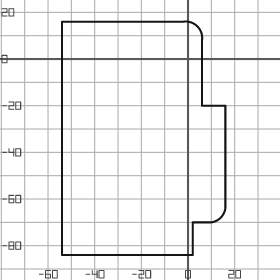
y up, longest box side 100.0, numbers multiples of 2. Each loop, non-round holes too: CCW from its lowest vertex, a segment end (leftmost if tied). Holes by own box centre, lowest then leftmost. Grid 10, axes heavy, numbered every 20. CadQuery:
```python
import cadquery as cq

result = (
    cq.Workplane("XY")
    .moveTo(-54.0, -84.0)
    .lineTo(2.0, -84.0)
    .lineTo(2.0, -70.0)
    .lineTo(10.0, -70.0)
    .threePointArc((14.0, -68.0), (16.0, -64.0))
    .lineTo(16.0, -20.0)
    .lineTo(6.0, -20.0)
    .lineTo(6.0, 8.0)
    .threePointArc((4.0, 14.0), (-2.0, 16.0))
    .lineTo(-54.0, 16.0)
    .close()
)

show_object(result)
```